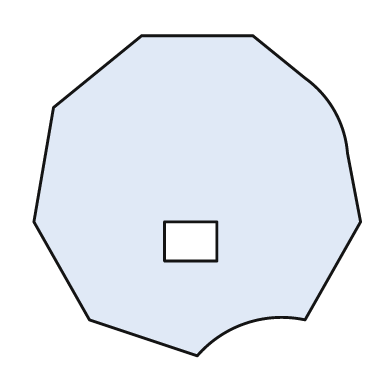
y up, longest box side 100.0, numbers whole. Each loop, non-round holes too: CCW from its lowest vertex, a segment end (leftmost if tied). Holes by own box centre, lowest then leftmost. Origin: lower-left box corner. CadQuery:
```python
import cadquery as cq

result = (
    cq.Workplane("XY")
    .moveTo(50.0, 0.0)
    .threePointArc((65.0, 10.0), (83.0, 11.0))
    .lineTo(100.0, 41.0)
    .lineTo(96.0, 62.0)
    .threePointArc((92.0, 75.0), (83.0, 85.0))
    .lineTo(67.0, 98.0)
    .lineTo(33.0, 98.0)
    .lineTo(6.0, 76.0)
    .lineTo(0.0, 41.0)
    .lineTo(17.0, 11.0)
    .close()
    .moveTo(40.0, 29.0)
    .lineTo(56.0, 29.0)
    .lineTo(56.0, 41.0)
    .lineTo(40.0, 41.0)
    .close()
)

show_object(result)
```